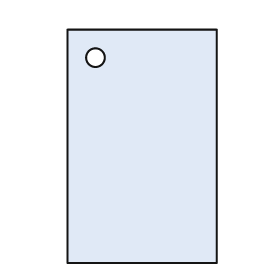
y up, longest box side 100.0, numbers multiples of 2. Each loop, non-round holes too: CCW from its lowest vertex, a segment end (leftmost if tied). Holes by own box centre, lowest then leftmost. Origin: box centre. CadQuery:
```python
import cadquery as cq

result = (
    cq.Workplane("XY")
    .moveTo(-32.0, -50.0)
    .lineTo(32.0, -50.0)
    .lineTo(32.0, 50.0)
    .lineTo(-32.0, 50.0)
    .close()
    .moveTo(-20.0, 38.0)
    .circle(4.0)
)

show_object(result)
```